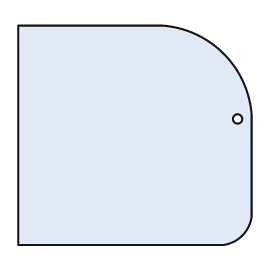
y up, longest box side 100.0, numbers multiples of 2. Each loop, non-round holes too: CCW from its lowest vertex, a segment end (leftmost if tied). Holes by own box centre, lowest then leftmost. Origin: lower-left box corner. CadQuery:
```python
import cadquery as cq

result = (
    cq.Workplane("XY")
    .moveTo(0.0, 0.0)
    .lineTo(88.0, 0.0)
    .threePointArc((96.0, 4.0), (100.0, 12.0))
    .lineTo(100.0, 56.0)
    .threePointArc((88.0, 82.0), (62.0, 94.0))
    .lineTo(0.0, 94.0)
    .close()
    .moveTo(94.0, 54.0)
    .circle(2.0)
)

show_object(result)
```